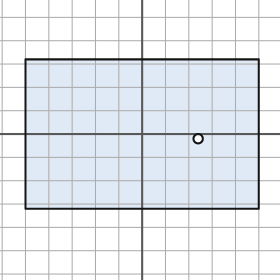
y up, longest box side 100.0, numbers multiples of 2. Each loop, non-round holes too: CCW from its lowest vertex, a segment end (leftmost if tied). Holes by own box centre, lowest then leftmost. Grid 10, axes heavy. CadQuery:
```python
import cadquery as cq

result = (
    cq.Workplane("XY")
    .moveTo(-50.0, -32.0)
    .lineTo(50.0, -32.0)
    .lineTo(50.0, 32.0)
    .lineTo(-50.0, 32.0)
    .close()
    .moveTo(24.0, -2.0)
    .circle(2.0)
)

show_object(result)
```